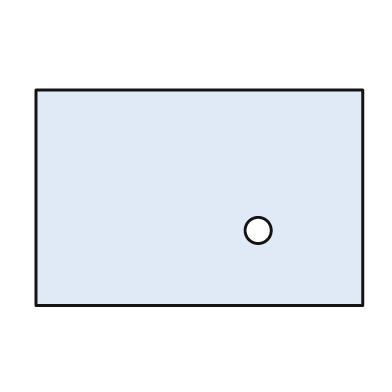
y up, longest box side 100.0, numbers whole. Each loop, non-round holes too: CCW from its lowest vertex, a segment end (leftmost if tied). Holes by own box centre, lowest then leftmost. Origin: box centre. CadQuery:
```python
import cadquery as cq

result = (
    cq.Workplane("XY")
    .moveTo(-50.0, -33.0)
    .lineTo(50.0, -33.0)
    .lineTo(50.0, 33.0)
    .lineTo(-50.0, 33.0)
    .close()
    .moveTo(18.0, -10.0)
    .circle(4.0)
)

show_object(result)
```